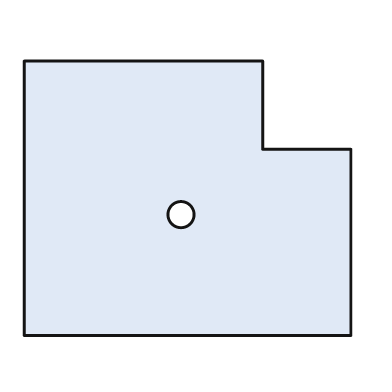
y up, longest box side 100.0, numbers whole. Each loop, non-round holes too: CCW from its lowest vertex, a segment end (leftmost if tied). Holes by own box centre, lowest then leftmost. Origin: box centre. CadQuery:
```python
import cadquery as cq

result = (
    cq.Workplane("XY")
    .moveTo(-50.0, -42.0)
    .lineTo(50.0, -42.0)
    .lineTo(50.0, 15.0)
    .lineTo(23.0, 15.0)
    .lineTo(23.0, 42.0)
    .lineTo(-50.0, 42.0)
    .close()
    .moveTo(-2.0, -5.0)
    .circle(4.0)
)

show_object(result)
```